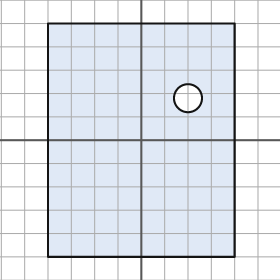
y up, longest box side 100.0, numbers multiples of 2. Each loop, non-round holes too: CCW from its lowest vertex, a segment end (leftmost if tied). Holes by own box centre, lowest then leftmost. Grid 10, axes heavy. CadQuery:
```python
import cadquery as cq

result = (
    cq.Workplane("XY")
    .moveTo(-40.0, -50.0)
    .lineTo(40.0, -50.0)
    .lineTo(40.0, 50.0)
    .lineTo(-40.0, 50.0)
    .close()
    .moveTo(20.0, 18.0)
    .circle(6.0)
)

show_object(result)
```